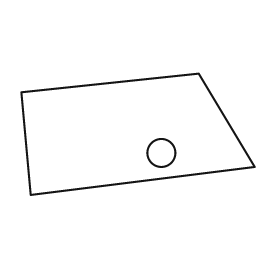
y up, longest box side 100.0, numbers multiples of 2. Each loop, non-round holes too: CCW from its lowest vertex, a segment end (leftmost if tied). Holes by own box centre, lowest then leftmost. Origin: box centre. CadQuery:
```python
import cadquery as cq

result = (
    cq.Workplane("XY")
    .moveTo(-46.0, -26.0)
    .lineTo(50.0, -14.0)
    .lineTo(26.0, 26.0)
    .lineTo(-50.0, 18.0)
    .close()
    .moveTo(10.0, -8.0)
    .circle(6.0)
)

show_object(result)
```